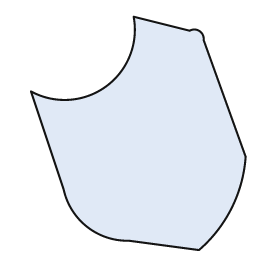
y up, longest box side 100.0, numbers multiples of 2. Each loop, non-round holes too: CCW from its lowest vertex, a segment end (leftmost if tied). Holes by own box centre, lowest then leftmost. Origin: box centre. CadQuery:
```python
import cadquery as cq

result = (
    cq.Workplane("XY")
    .moveTo(26.0, -50.0)
    .threePointArc((40.0, -32.0), (46.0, -10.0))
    .lineTo(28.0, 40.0)
    .threePointArc((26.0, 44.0), (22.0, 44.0))
    .lineTo(-2.0, 50.0)
    .threePointArc((-14.0, 20.0), (-46.0, 18.0))
    .lineTo(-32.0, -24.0)
    .threePointArc((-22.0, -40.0), (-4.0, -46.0))
    .close()
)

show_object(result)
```